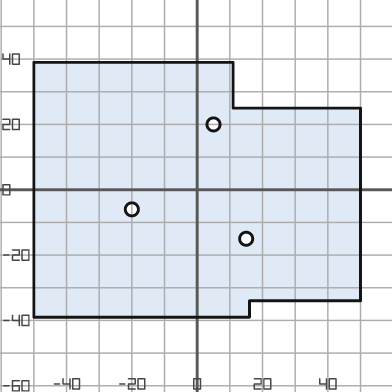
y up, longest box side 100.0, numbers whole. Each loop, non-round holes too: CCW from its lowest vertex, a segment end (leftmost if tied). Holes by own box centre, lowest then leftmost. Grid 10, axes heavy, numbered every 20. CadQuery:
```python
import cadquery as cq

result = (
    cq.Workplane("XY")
    .moveTo(-50.0, -39.0)
    .lineTo(16.0, -39.0)
    .lineTo(16.0, -34.0)
    .lineTo(50.0, -34.0)
    .lineTo(50.0, 25.0)
    .lineTo(11.0, 25.0)
    .lineTo(11.0, 39.0)
    .lineTo(-50.0, 39.0)
    .close()
    .moveTo(15.0, -15.0)
    .circle(2.0)
    .moveTo(-20.0, -6.0)
    .circle(2.0)
    .moveTo(5.0, 20.0)
    .circle(2.0)
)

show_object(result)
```